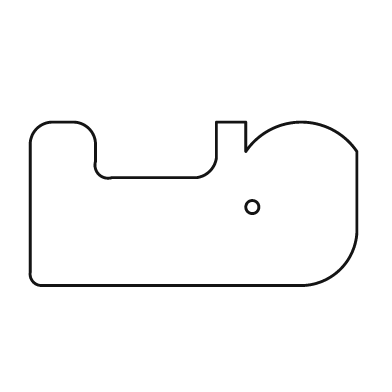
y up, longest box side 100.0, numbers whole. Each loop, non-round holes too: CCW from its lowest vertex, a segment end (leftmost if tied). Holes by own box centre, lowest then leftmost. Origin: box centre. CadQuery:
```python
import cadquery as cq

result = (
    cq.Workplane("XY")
    .moveTo(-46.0, -25.0)
    .lineTo(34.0, -25.0)
    .threePointArc((45.0, -20.0), (50.0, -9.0))
    .lineTo(50.0, 16.0)
    .threePointArc((33.0, 25.0), (16.0, 16.0))
    .lineTo(16.0, 25.0)
    .lineTo(7.0, 25.0)
    .lineTo(7.0, 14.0)
    .threePointArc((5.0, 10.0), (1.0, 8.0))
    .lineTo(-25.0, 8.0)
    .threePointArc((-29.0, 9.0), (-30.0, 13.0))
    .lineTo(-30.0, 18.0)
    .threePointArc((-32.0, 23.0), (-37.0, 25.0))
    .lineTo(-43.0, 25.0)
    .threePointArc((-48.0, 23.0), (-50.0, 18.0))
    .lineTo(-50.0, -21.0)
    .threePointArc((-49.0, -24.0), (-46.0, -25.0))
    .close()
    .moveTo(18.0, -1.0)
    .circle(2.0)
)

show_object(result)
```